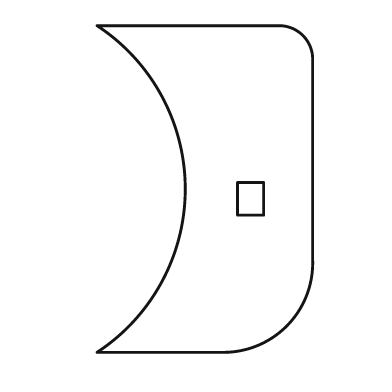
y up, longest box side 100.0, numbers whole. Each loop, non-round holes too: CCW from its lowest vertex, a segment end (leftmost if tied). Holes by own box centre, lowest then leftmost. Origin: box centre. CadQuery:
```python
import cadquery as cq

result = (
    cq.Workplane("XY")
    .moveTo(-33.0, -50.0)
    .lineTo(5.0, -50.0)
    .threePointArc((25.0, -42.0), (33.0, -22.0))
    .lineTo(33.0, 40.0)
    .threePointArc((30.0, 47.0), (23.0, 50.0))
    .lineTo(-33.0, 50.0)
    .threePointArc((-6.0, 0.0), (-33.0, -50.0))
    .close()
    .moveTo(10.0, -8.0)
    .lineTo(18.0, -8.0)
    .lineTo(18.0, 2.0)
    .lineTo(10.0, 2.0)
    .close()
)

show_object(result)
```